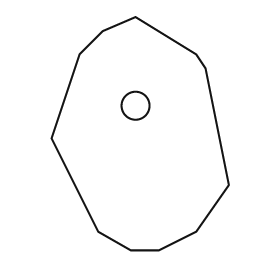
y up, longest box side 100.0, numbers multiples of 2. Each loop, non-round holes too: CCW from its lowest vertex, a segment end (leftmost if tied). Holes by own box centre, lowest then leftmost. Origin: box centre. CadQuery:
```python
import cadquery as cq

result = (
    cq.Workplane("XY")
    .moveTo(-4.0, -50.0)
    .lineTo(8.0, -50.0)
    .lineTo(24.0, -42.0)
    .lineTo(38.0, -22.0)
    .lineTo(28.0, 28.0)
    .lineTo(24.0, 34.0)
    .lineTo(-2.0, 50.0)
    .lineTo(-16.0, 44.0)
    .lineTo(-26.0, 34.0)
    .lineTo(-38.0, -2.0)
    .lineTo(-18.0, -42.0)
    .close()
    .moveTo(-2.0, 12.0)
    .circle(6.0)
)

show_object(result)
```